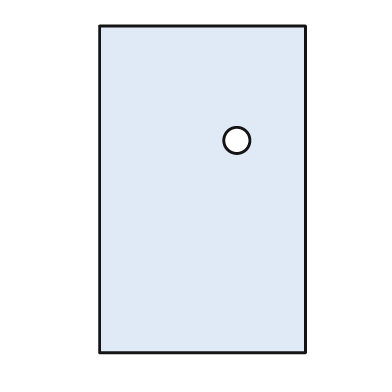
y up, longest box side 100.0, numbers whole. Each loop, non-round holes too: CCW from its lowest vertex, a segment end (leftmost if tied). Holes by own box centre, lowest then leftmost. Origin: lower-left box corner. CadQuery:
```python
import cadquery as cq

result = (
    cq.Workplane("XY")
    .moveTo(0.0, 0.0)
    .lineTo(63.0, 0.0)
    .lineTo(63.0, 100.0)
    .lineTo(0.0, 100.0)
    .close()
    .moveTo(42.0, 65.0)
    .circle(4.0)
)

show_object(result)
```